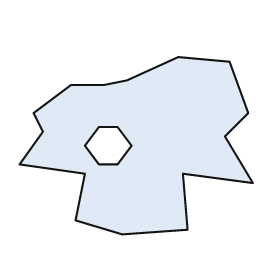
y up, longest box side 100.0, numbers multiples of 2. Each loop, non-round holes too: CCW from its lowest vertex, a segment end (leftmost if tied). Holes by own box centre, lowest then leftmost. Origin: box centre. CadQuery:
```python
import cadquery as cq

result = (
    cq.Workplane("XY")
    .moveTo(-6.0, -38.0)
    .lineTo(22.0, -36.0)
    .lineTo(20.0, -12.0)
    .lineTo(50.0, -16.0)
    .lineTo(38.0, 4.0)
    .lineTo(48.0, 14.0)
    .lineTo(40.0, 36.0)
    .lineTo(18.0, 38.0)
    .lineTo(-4.0, 28.0)
    .lineTo(-14.0, 26.0)
    .lineTo(-28.0, 26.0)
    .lineTo(-44.0, 14.0)
    .lineTo(-40.0, 6.0)
    .lineTo(-50.0, -8.0)
    .lineTo(-22.0, -12.0)
    .lineTo(-26.0, -32.0)
    .close()
    .moveTo(-16.0, -8.0)
    .lineTo(-8.0, -8.0)
    .lineTo(-2.0, 0.0)
    .lineTo(-8.0, 8.0)
    .lineTo(-16.0, 8.0)
    .lineTo(-22.0, 0.0)
    .close()
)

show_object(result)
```